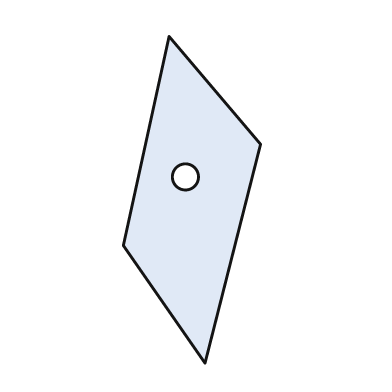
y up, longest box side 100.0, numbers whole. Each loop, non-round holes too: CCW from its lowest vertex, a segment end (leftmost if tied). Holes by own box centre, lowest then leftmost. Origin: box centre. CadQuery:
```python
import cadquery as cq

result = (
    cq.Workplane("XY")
    .moveTo(4.0, -50.0)
    .lineTo(21.0, 17.0)
    .lineTo(-7.0, 50.0)
    .lineTo(-21.0, -14.0)
    .close()
    .moveTo(-2.0, 7.0)
    .circle(4.0)
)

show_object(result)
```